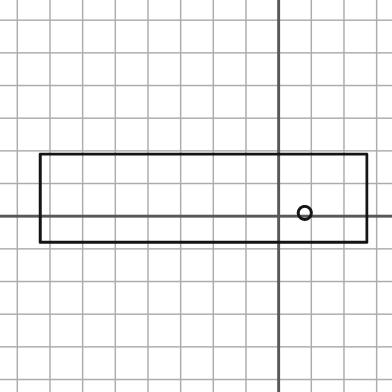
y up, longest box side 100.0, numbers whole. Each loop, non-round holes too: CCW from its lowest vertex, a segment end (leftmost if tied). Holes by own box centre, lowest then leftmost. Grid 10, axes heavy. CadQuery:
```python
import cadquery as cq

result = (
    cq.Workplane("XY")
    .moveTo(-73.0, -8.0)
    .lineTo(27.0, -8.0)
    .lineTo(27.0, 19.0)
    .lineTo(-73.0, 19.0)
    .close()
    .moveTo(8.0, 1.0)
    .circle(2.0)
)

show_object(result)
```